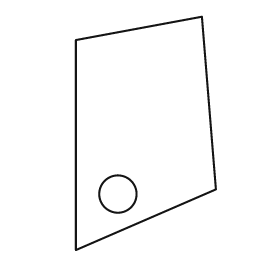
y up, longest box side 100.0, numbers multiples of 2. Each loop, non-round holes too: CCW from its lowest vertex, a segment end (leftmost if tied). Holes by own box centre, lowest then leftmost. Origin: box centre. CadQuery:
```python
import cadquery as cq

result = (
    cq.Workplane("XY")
    .moveTo(-30.0, -50.0)
    .lineTo(30.0, -24.0)
    .lineTo(24.0, 50.0)
    .lineTo(-30.0, 40.0)
    .close()
    .moveTo(-12.0, -26.0)
    .circle(8.0)
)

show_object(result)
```